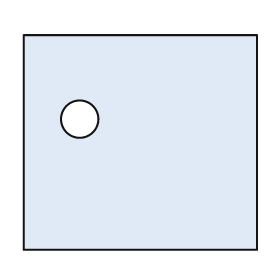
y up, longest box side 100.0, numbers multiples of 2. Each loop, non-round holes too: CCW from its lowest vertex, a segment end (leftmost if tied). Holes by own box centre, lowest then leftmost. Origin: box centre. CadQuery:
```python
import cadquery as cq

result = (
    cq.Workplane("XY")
    .moveTo(-50.0, -46.0)
    .lineTo(50.0, -46.0)
    .lineTo(50.0, 46.0)
    .lineTo(-50.0, 46.0)
    .close()
    .moveTo(-26.0, 10.0)
    .circle(8.0)
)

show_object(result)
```